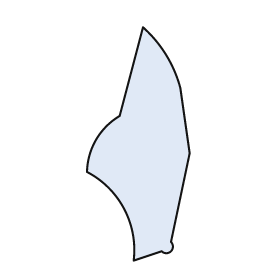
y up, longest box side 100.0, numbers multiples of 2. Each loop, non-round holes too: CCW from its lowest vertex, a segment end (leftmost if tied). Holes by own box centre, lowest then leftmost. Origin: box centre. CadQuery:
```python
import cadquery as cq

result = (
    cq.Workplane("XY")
    .moveTo(-2.0, -50.0)
    .lineTo(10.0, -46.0)
    .threePointArc((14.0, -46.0), (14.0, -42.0))
    .lineTo(22.0, -4.0)
    .lineTo(18.0, 24.0)
    .threePointArc((12.0, 38.0), (2.0, 50.0))
    .lineTo(-8.0, 12.0)
    .threePointArc((-18.0, 2.0), (-22.0, -12.0))
    .threePointArc((-6.0, -28.0), (-2.0, -50.0))
    .close()
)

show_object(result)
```